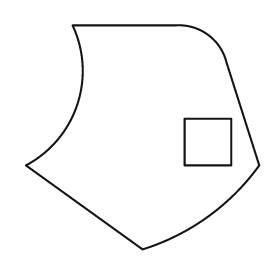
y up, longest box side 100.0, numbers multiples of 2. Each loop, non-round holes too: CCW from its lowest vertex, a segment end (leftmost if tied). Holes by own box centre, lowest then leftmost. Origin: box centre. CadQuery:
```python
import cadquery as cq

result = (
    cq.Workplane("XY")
    .moveTo(0.0, -48.0)
    .threePointArc((28.0, -34.0), (50.0, -12.0))
    .lineTo(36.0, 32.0)
    .threePointArc((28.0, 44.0), (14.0, 48.0))
    .lineTo(-30.0, 48.0)
    .threePointArc((-28.0, 14.0), (-50.0, -12.0))
    .close()
    .moveTo(18.0, -12.0)
    .lineTo(38.0, -12.0)
    .lineTo(38.0, 8.0)
    .lineTo(18.0, 8.0)
    .close()
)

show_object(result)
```